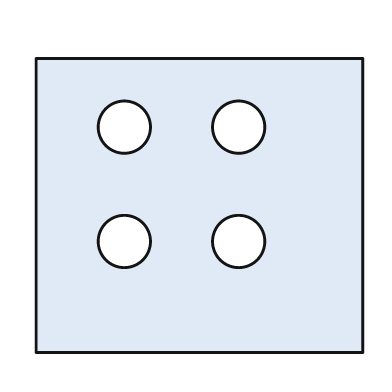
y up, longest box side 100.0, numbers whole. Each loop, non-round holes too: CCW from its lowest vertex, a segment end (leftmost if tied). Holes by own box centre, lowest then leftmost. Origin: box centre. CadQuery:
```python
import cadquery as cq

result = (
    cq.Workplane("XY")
    .moveTo(-50.0, -45.0)
    .lineTo(50.0, -45.0)
    .lineTo(50.0, 45.0)
    .lineTo(-50.0, 45.0)
    .close()
    .moveTo(-23.0, -11.0)
    .circle(8.0)
    .moveTo(12.0, -11.0)
    .circle(8.0)
    .moveTo(-23.0, 24.0)
    .circle(8.0)
    .moveTo(12.0, 24.0)
    .circle(8.0)
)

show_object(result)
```